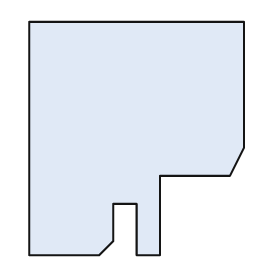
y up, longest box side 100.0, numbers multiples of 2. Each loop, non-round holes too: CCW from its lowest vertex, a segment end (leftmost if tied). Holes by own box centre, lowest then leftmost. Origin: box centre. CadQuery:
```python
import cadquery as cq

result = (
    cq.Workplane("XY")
    .moveTo(-46.0, -50.0)
    .lineTo(-16.0, -50.0)
    .lineTo(-10.0, -44.0)
    .lineTo(-10.0, -28.0)
    .lineTo(0.0, -28.0)
    .lineTo(0.0, -50.0)
    .lineTo(10.0, -50.0)
    .lineTo(10.0, -16.0)
    .lineTo(40.0, -16.0)
    .lineTo(46.0, -4.0)
    .lineTo(46.0, 50.0)
    .lineTo(-46.0, 50.0)
    .close()
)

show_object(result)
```